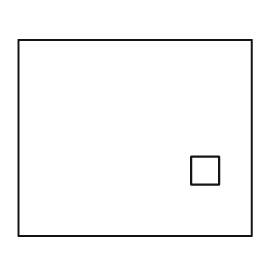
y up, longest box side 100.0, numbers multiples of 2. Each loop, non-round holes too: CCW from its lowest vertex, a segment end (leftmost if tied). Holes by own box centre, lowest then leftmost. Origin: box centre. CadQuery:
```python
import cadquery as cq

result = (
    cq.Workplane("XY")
    .moveTo(-50.0, -42.0)
    .lineTo(50.0, -42.0)
    .lineTo(50.0, 42.0)
    .lineTo(-50.0, 42.0)
    .close()
    .moveTo(24.0, -20.0)
    .lineTo(36.0, -20.0)
    .lineTo(36.0, -8.0)
    .lineTo(24.0, -8.0)
    .close()
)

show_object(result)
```